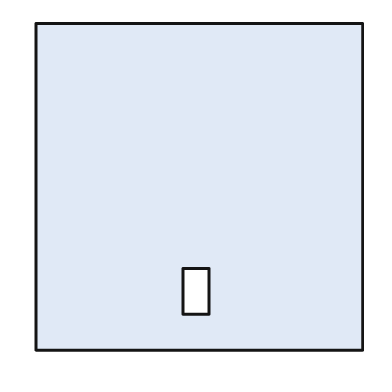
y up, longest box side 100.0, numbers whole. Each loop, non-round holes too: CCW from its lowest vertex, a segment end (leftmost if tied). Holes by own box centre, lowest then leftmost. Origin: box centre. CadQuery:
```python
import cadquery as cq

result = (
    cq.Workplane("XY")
    .moveTo(-50.0, -50.0)
    .lineTo(50.0, -50.0)
    .lineTo(50.0, 50.0)
    .lineTo(-50.0, 50.0)
    .close()
    .moveTo(-5.0, -39.0)
    .lineTo(3.0, -39.0)
    .lineTo(3.0, -25.0)
    .lineTo(-5.0, -25.0)
    .close()
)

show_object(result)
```